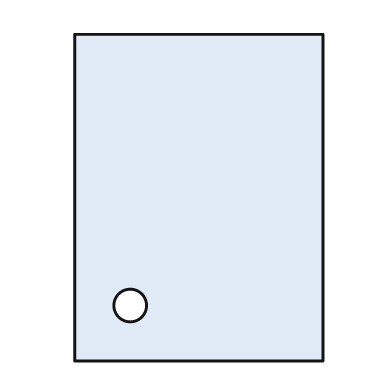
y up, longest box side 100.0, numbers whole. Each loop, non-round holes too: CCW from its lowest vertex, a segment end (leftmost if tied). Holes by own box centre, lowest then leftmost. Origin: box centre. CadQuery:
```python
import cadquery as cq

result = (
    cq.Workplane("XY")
    .moveTo(-38.0, -50.0)
    .lineTo(38.0, -50.0)
    .lineTo(38.0, 50.0)
    .lineTo(-38.0, 50.0)
    .close()
    .moveTo(-21.0, -33.0)
    .circle(5.0)
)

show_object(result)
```